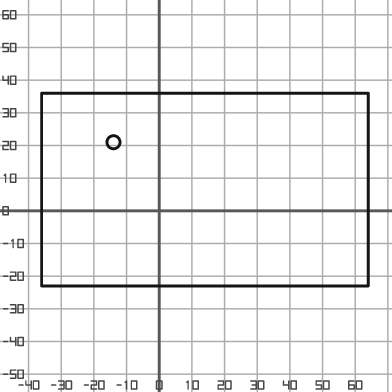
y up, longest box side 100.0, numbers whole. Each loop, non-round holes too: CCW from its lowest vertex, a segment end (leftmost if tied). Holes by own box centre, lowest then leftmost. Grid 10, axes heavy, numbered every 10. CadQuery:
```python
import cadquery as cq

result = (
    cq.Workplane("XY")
    .moveTo(-36.0, -23.0)
    .lineTo(64.0, -23.0)
    .lineTo(64.0, 36.0)
    .lineTo(-36.0, 36.0)
    .close()
    .moveTo(-14.0, 21.0)
    .circle(2.0)
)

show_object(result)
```